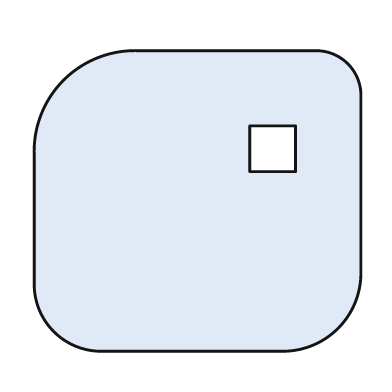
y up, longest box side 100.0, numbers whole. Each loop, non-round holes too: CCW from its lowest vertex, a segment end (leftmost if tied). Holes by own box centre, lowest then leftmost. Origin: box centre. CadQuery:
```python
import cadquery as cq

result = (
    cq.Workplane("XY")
    .moveTo(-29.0, -46.0)
    .lineTo(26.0, -46.0)
    .threePointArc((43.0, -39.0), (50.0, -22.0))
    .lineTo(50.0, 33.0)
    .threePointArc((46.0, 42.0), (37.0, 46.0))
    .lineTo(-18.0, 46.0)
    .threePointArc((-41.0, 37.0), (-50.0, 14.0))
    .lineTo(-50.0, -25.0)
    .threePointArc((-44.0, -40.0), (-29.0, -46.0))
    .close()
    .moveTo(16.0, 9.0)
    .lineTo(30.0, 9.0)
    .lineTo(30.0, 23.0)
    .lineTo(16.0, 23.0)
    .close()
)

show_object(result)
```